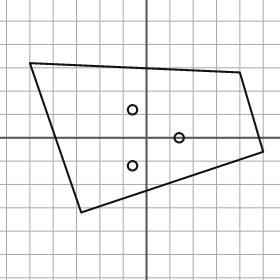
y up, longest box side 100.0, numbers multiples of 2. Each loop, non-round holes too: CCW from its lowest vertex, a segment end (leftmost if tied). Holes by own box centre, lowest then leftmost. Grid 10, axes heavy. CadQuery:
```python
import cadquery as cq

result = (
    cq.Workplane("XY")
    .moveTo(-28.0, -32.0)
    .lineTo(50.0, -6.0)
    .lineTo(40.0, 28.0)
    .lineTo(-50.0, 32.0)
    .close()
    .moveTo(-6.0, -12.0)
    .circle(2.0)
    .moveTo(14.0, 0.0)
    .circle(2.0)
    .moveTo(-6.0, 12.0)
    .circle(2.0)
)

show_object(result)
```